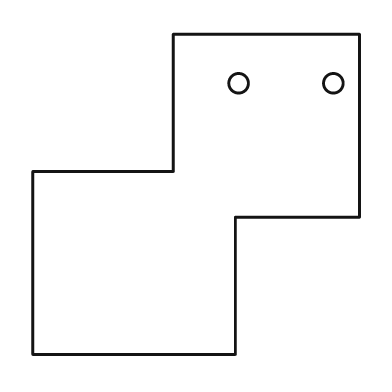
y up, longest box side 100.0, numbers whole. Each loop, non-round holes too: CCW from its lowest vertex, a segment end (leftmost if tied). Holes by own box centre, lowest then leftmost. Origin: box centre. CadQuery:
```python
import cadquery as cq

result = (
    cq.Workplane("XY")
    .moveTo(-50.0, -49.0)
    .lineTo(12.0, -49.0)
    .lineTo(12.0, -7.0)
    .lineTo(50.0, -7.0)
    .lineTo(50.0, 49.0)
    .lineTo(-7.0, 49.0)
    .lineTo(-7.0, 7.0)
    .lineTo(-50.0, 7.0)
    .close()
    .moveTo(13.0, 34.0)
    .circle(3.0)
    .moveTo(42.0, 34.0)
    .circle(3.0)
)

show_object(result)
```